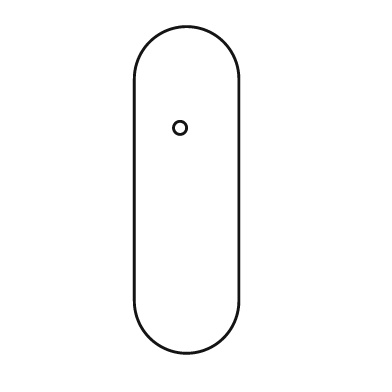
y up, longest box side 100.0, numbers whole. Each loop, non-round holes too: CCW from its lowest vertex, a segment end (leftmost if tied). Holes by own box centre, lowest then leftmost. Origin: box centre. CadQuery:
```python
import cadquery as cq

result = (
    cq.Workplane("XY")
    .moveTo(-16.0, -34.0)
    .threePointArc((0.0, -50.0), (16.0, -34.0))
    .lineTo(16.0, 34.0)
    .threePointArc((0.0, 50.0), (-16.0, 34.0))
    .close()
    .moveTo(-2.0, 19.0)
    .circle(2.0)
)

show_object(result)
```